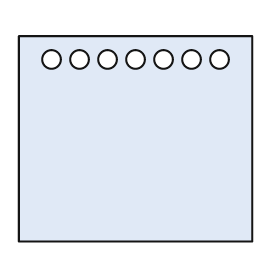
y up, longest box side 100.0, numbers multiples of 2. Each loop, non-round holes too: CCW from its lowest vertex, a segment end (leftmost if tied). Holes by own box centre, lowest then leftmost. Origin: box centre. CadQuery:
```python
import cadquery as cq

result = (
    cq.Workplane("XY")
    .moveTo(-50.0, -44.0)
    .lineTo(50.0, -44.0)
    .lineTo(50.0, 44.0)
    .lineTo(-50.0, 44.0)
    .close()
    .moveTo(-36.0, 34.0)
    .circle(4.0)
    .moveTo(-24.0, 34.0)
    .circle(4.0)
    .moveTo(-12.0, 34.0)
    .circle(4.0)
    .moveTo(0.0, 34.0)
    .circle(4.0)
    .moveTo(12.0, 34.0)
    .circle(4.0)
    .moveTo(24.0, 34.0)
    .circle(4.0)
    .moveTo(36.0, 34.0)
    .circle(4.0)
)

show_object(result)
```